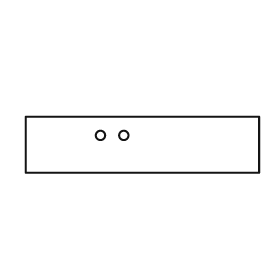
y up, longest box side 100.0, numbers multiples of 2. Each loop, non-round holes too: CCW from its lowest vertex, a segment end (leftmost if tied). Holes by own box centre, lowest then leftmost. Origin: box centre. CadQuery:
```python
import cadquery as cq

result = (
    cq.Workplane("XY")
    .moveTo(-50.0, -12.0)
    .lineTo(50.0, -12.0)
    .lineTo(50.0, 12.0)
    .lineTo(-50.0, 12.0)
    .close()
    .moveTo(-18.0, 4.0)
    .circle(2.0)
    .moveTo(-8.0, 4.0)
    .circle(2.0)
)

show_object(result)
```